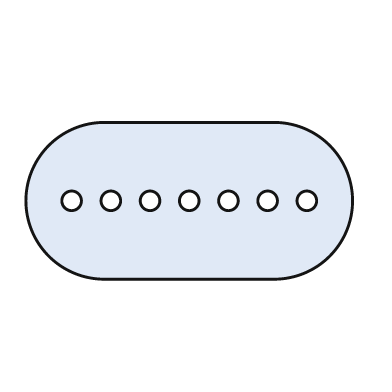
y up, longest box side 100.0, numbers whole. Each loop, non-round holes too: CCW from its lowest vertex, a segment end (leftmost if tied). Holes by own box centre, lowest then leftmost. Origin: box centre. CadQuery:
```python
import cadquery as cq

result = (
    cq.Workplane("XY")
    .moveTo(-26.0, -24.0)
    .lineTo(26.0, -24.0)
    .threePointArc((50.0, 0.0), (26.0, 24.0))
    .lineTo(-26.0, 24.0)
    .threePointArc((-50.0, 0.0), (-26.0, -24.0))
    .close()
    .moveTo(-36.0, 0.0)
    .circle(3.0)
    .moveTo(-24.0, 0.0)
    .circle(3.0)
    .moveTo(-12.0, 0.0)
    .circle(3.0)
    .moveTo(0.0, 0.0)
    .circle(3.0)
    .moveTo(12.0, 0.0)
    .circle(3.0)
    .moveTo(24.0, 0.0)
    .circle(3.0)
    .moveTo(36.0, 0.0)
    .circle(3.0)
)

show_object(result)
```